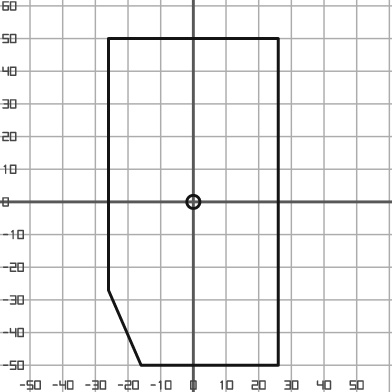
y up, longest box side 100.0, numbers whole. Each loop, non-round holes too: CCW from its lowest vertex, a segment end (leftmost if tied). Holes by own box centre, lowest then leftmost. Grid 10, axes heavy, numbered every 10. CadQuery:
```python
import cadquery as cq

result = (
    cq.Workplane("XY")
    .moveTo(-16.0, -50.0)
    .lineTo(26.0, -50.0)
    .lineTo(26.0, 50.0)
    .lineTo(-26.0, 50.0)
    .lineTo(-26.0, -27.0)
    .close()
    .moveTo(0.0, 0.0)
    .circle(2.0)
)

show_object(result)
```